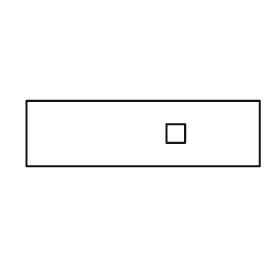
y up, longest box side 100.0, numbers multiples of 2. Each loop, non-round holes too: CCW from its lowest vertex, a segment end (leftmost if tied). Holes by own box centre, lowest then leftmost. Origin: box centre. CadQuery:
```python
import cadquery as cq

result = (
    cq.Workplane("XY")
    .moveTo(-50.0, -14.0)
    .lineTo(50.0, -14.0)
    .lineTo(50.0, 14.0)
    .lineTo(-50.0, 14.0)
    .close()
    .moveTo(10.0, -4.0)
    .lineTo(18.0, -4.0)
    .lineTo(18.0, 4.0)
    .lineTo(10.0, 4.0)
    .close()
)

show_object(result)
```